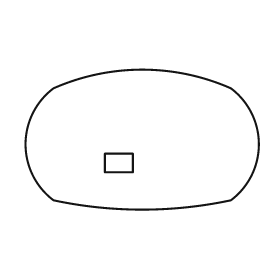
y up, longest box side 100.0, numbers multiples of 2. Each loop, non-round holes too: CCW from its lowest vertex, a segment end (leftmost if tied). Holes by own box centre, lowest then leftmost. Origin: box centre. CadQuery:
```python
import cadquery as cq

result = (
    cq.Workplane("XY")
    .moveTo(-38.0, -26.0)
    .threePointArc((0.0, -30.0), (38.0, -26.0))
    .threePointArc((50.0, -2.0), (38.0, 22.0))
    .threePointArc((0.0, 30.0), (-38.0, 22.0))
    .threePointArc((-50.0, -2.0), (-38.0, -26.0))
    .close()
    .moveTo(-16.0, -14.0)
    .lineTo(-4.0, -14.0)
    .lineTo(-4.0, -6.0)
    .lineTo(-16.0, -6.0)
    .close()
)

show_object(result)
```